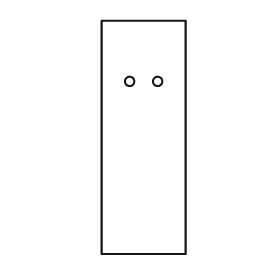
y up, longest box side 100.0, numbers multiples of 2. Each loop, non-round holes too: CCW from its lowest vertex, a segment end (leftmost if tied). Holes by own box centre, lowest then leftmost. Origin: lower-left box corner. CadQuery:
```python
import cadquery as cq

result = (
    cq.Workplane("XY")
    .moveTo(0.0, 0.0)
    .lineTo(36.0, 0.0)
    .lineTo(36.0, 100.0)
    .lineTo(0.0, 100.0)
    .close()
    .moveTo(12.0, 74.0)
    .circle(2.0)
    .moveTo(24.0, 74.0)
    .circle(2.0)
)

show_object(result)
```